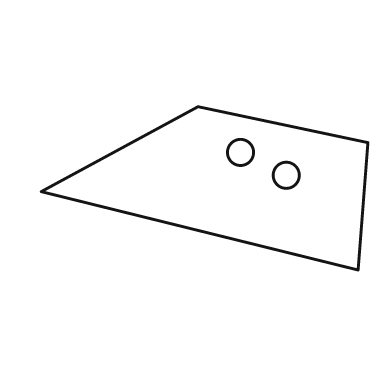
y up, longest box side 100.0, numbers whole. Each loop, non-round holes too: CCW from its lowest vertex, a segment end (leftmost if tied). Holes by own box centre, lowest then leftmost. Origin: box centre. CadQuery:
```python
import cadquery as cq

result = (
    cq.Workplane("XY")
    .moveTo(47.0, -25.0)
    .lineTo(50.0, 14.0)
    .lineTo(-2.0, 25.0)
    .lineTo(-50.0, -1.0)
    .close()
    .moveTo(25.0, 4.0)
    .circle(4.0)
    .moveTo(11.0, 11.0)
    .circle(4.0)
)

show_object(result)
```